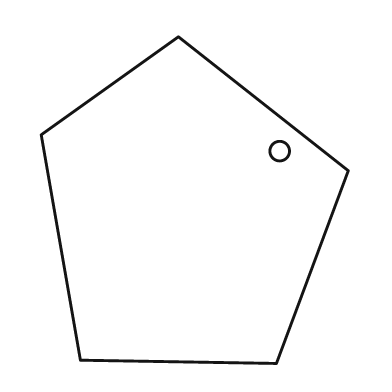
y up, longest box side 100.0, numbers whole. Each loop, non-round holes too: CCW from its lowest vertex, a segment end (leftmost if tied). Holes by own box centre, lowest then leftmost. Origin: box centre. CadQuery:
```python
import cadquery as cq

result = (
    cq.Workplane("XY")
    .moveTo(25.0, -50.0)
    .lineTo(47.0, 9.0)
    .lineTo(-5.0, 50.0)
    .lineTo(-47.0, 20.0)
    .lineTo(-35.0, -49.0)
    .close()
    .moveTo(26.0, 15.0)
    .circle(3.0)
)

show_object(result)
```